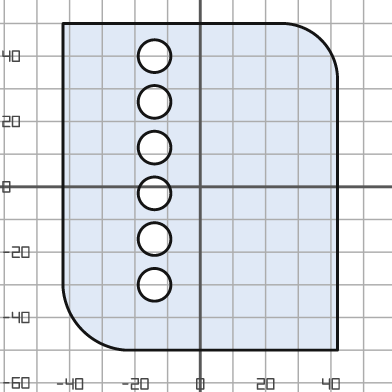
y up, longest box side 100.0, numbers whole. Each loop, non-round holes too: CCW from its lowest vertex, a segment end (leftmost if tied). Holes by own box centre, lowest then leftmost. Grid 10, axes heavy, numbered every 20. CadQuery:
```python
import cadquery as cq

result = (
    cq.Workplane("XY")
    .moveTo(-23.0, -50.0)
    .lineTo(42.0, -50.0)
    .lineTo(42.0, 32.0)
    .threePointArc((37.0, 45.0), (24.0, 50.0))
    .lineTo(-42.0, 50.0)
    .lineTo(-42.0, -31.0)
    .threePointArc((-36.0, -44.0), (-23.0, -50.0))
    .close()
    .moveTo(-14.0, -30.0)
    .circle(5.0)
    .moveTo(-14.0, -16.0)
    .circle(5.0)
    .moveTo(-14.0, -2.0)
    .circle(5.0)
    .moveTo(-14.0, 12.0)
    .circle(5.0)
    .moveTo(-14.0, 26.0)
    .circle(5.0)
    .moveTo(-14.0, 40.0)
    .circle(5.0)
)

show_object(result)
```